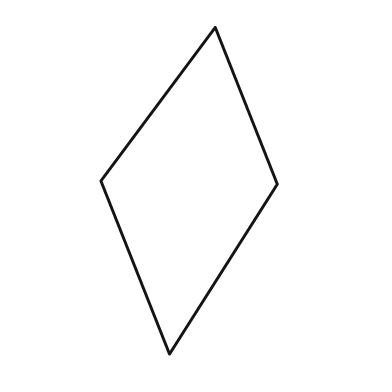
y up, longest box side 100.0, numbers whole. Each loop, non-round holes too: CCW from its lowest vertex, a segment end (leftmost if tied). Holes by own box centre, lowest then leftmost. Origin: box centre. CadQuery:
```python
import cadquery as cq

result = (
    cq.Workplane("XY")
    .moveTo(-6.0, -50.0)
    .lineTo(27.0, 2.0)
    .lineTo(8.0, 50.0)
    .lineTo(-27.0, 3.0)
    .close()
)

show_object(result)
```